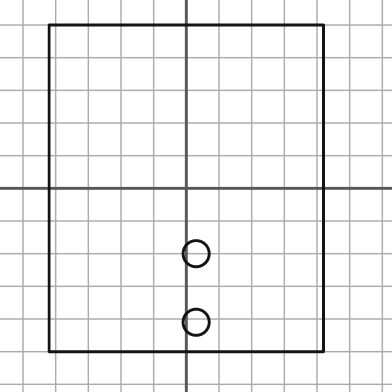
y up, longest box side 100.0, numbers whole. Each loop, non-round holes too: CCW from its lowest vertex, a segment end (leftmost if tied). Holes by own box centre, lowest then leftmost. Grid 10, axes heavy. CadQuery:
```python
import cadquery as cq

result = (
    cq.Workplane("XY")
    .moveTo(-42.0, -50.0)
    .lineTo(42.0, -50.0)
    .lineTo(42.0, 50.0)
    .lineTo(-42.0, 50.0)
    .close()
    .moveTo(3.0, -41.0)
    .circle(4.0)
    .moveTo(3.0, -20.0)
    .circle(4.0)
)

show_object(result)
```